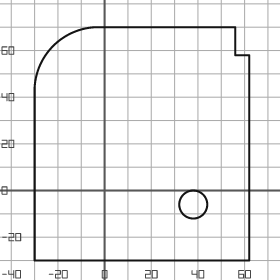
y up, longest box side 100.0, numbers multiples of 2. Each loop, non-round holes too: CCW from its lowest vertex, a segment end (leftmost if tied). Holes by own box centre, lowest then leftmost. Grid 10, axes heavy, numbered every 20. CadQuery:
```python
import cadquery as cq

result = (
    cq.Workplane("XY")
    .moveTo(-30.0, -30.0)
    .lineTo(62.0, -30.0)
    .lineTo(62.0, 58.0)
    .lineTo(56.0, 58.0)
    .lineTo(56.0, 70.0)
    .lineTo(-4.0, 70.0)
    .threePointArc((-22.0, 62.0), (-30.0, 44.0))
    .close()
    .moveTo(38.0, -6.0)
    .circle(6.0)
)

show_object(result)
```